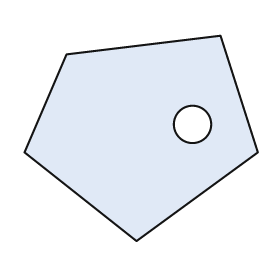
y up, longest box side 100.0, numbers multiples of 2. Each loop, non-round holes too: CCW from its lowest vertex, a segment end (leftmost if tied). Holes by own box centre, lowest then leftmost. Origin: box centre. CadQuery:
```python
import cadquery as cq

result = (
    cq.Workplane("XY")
    .moveTo(-2.0, -44.0)
    .lineTo(50.0, -6.0)
    .lineTo(34.0, 44.0)
    .lineTo(-32.0, 36.0)
    .lineTo(-50.0, -6.0)
    .close()
    .moveTo(22.0, 6.0)
    .circle(8.0)
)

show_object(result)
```